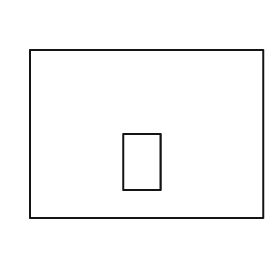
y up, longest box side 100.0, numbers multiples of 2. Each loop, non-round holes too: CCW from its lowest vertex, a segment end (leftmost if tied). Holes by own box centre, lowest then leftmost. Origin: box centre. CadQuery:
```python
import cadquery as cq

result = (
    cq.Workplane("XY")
    .moveTo(-50.0, -36.0)
    .lineTo(50.0, -36.0)
    .lineTo(50.0, 36.0)
    .lineTo(-50.0, 36.0)
    .close()
    .moveTo(-10.0, -24.0)
    .lineTo(6.0, -24.0)
    .lineTo(6.0, 0.0)
    .lineTo(-10.0, 0.0)
    .close()
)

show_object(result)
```